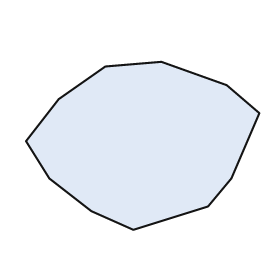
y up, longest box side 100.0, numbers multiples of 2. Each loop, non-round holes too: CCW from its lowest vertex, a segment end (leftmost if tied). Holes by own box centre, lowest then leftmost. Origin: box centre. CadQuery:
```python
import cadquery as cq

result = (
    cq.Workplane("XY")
    .moveTo(-4.0, -36.0)
    .lineTo(28.0, -26.0)
    .lineTo(38.0, -14.0)
    .lineTo(50.0, 14.0)
    .lineTo(36.0, 26.0)
    .lineTo(8.0, 36.0)
    .lineTo(-16.0, 34.0)
    .lineTo(-36.0, 20.0)
    .lineTo(-50.0, 2.0)
    .lineTo(-40.0, -14.0)
    .lineTo(-22.0, -28.0)
    .close()
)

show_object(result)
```